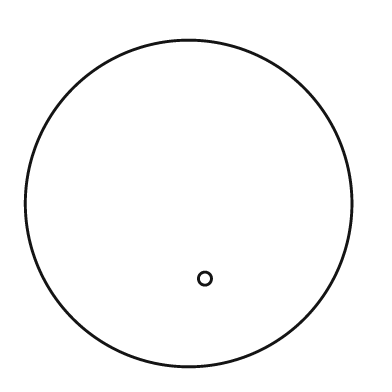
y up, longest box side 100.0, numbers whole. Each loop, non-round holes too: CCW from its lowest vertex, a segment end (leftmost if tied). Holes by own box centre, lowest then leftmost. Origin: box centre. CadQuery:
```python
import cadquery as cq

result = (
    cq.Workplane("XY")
    .moveTo(0.0, 0.0)
    .circle(50.0)
    .moveTo(5.0, -23.0)
    .circle(2.0)
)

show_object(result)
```